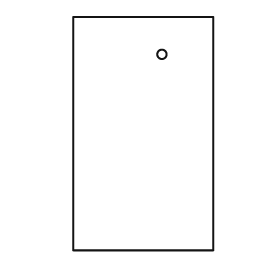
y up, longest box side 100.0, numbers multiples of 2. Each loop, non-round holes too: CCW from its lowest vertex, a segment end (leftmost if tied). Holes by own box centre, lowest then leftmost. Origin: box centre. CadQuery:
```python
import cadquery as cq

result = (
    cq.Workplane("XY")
    .moveTo(-30.0, -50.0)
    .lineTo(30.0, -50.0)
    .lineTo(30.0, 50.0)
    .lineTo(-30.0, 50.0)
    .close()
    .moveTo(8.0, 34.0)
    .circle(2.0)
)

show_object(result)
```